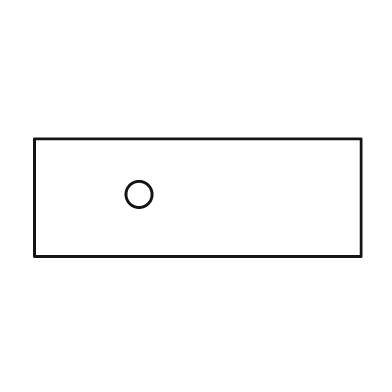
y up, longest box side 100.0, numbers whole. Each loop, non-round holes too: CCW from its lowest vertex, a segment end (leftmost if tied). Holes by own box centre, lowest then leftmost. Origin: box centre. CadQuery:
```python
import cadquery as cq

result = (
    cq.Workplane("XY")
    .moveTo(-50.0, -18.0)
    .lineTo(50.0, -18.0)
    .lineTo(50.0, 18.0)
    .lineTo(-50.0, 18.0)
    .close()
    .moveTo(-18.0, 1.0)
    .circle(4.0)
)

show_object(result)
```